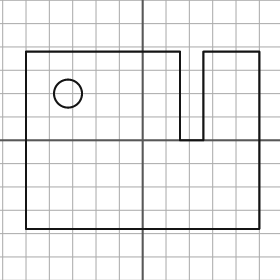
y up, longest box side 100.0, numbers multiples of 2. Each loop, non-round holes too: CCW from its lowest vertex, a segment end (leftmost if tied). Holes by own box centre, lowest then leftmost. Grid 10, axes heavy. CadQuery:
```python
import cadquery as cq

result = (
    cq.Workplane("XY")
    .moveTo(-50.0, -38.0)
    .lineTo(50.0, -38.0)
    .lineTo(50.0, 38.0)
    .lineTo(26.0, 38.0)
    .lineTo(26.0, 0.0)
    .lineTo(16.0, 0.0)
    .lineTo(16.0, 38.0)
    .lineTo(-50.0, 38.0)
    .close()
    .moveTo(-32.0, 20.0)
    .circle(6.0)
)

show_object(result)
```